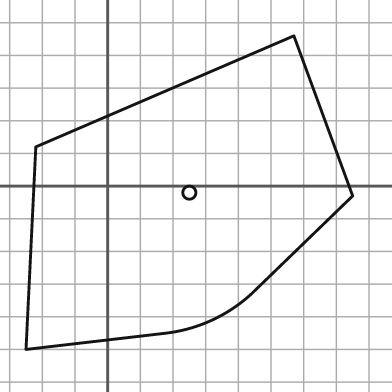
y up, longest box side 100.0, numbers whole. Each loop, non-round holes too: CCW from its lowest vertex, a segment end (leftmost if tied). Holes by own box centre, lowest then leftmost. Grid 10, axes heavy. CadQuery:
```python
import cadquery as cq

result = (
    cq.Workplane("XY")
    .moveTo(-25.0, -50.0)
    .lineTo(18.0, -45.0)
    .threePointArc((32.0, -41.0), (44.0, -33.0))
    .lineTo(75.0, -3.0)
    .lineTo(57.0, 46.0)
    .lineTo(-22.0, 12.0)
    .close()
    .moveTo(25.0, -2.0)
    .circle(2.0)
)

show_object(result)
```